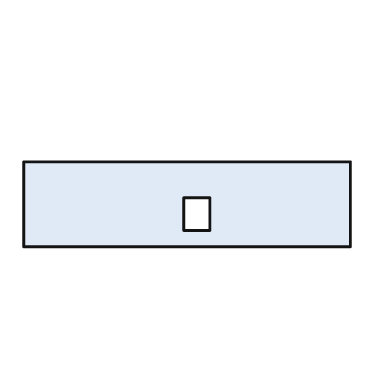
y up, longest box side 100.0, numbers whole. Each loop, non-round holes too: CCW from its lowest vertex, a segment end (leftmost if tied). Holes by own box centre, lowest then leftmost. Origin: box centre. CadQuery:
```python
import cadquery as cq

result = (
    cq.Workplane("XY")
    .moveTo(-50.0, -13.0)
    .lineTo(50.0, -13.0)
    .lineTo(50.0, 13.0)
    .lineTo(-50.0, 13.0)
    .close()
    .moveTo(-1.0, -8.0)
    .lineTo(7.0, -8.0)
    .lineTo(7.0, 2.0)
    .lineTo(-1.0, 2.0)
    .close()
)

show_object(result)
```